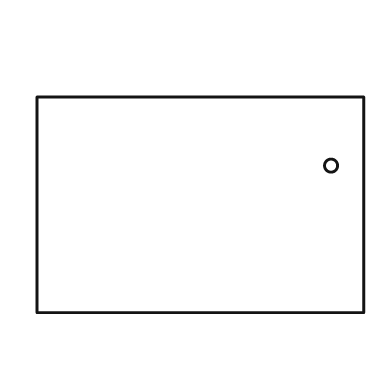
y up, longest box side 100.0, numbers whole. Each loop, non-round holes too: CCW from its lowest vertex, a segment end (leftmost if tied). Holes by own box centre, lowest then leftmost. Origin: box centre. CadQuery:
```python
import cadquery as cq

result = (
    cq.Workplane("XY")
    .moveTo(-50.0, -33.0)
    .lineTo(50.0, -33.0)
    .lineTo(50.0, 33.0)
    .lineTo(-50.0, 33.0)
    .close()
    .moveTo(40.0, 12.0)
    .circle(2.0)
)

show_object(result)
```